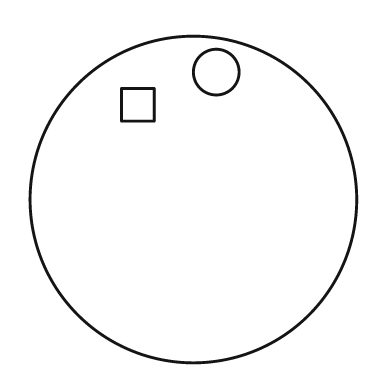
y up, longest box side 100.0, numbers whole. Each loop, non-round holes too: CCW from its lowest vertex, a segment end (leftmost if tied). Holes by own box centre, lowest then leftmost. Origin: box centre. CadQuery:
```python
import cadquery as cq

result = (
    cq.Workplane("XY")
    .moveTo(0.0, 0.0)
    .circle(50.0)
    .moveTo(-22.0, 24.0)
    .lineTo(-12.0, 24.0)
    .lineTo(-12.0, 34.0)
    .lineTo(-22.0, 34.0)
    .close()
    .moveTo(7.0, 39.0)
    .circle(7.0)
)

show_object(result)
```